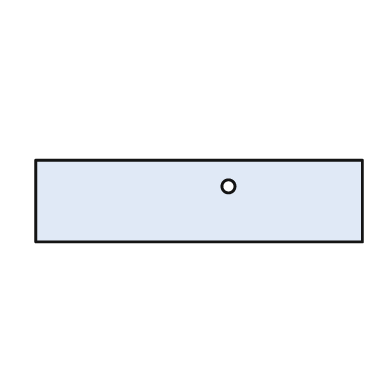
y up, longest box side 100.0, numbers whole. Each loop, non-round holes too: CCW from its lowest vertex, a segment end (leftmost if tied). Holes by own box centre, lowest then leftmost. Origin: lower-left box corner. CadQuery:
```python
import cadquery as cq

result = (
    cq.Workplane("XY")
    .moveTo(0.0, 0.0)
    .lineTo(100.0, 0.0)
    .lineTo(100.0, 25.0)
    .lineTo(0.0, 25.0)
    .close()
    .moveTo(59.0, 17.0)
    .circle(2.0)
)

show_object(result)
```